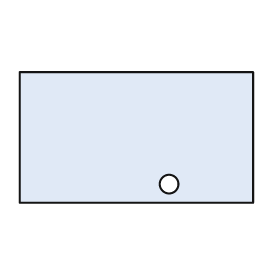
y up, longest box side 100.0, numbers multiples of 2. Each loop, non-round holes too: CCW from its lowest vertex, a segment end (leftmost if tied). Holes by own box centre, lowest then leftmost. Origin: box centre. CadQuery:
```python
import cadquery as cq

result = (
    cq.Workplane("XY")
    .moveTo(-50.0, -28.0)
    .lineTo(50.0, -28.0)
    .lineTo(50.0, 28.0)
    .lineTo(-50.0, 28.0)
    .close()
    .moveTo(14.0, -20.0)
    .circle(4.0)
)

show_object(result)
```